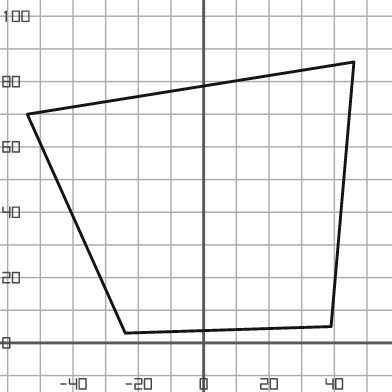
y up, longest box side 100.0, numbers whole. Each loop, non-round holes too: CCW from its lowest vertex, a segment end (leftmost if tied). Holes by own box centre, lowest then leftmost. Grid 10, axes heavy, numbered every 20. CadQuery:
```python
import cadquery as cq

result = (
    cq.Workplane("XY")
    .moveTo(-24.0, 3.0)
    .lineTo(39.0, 5.0)
    .lineTo(46.0, 86.0)
    .lineTo(-54.0, 70.0)
    .close()
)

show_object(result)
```